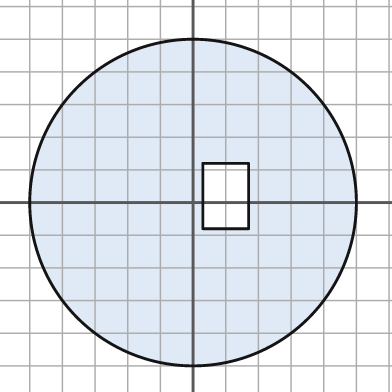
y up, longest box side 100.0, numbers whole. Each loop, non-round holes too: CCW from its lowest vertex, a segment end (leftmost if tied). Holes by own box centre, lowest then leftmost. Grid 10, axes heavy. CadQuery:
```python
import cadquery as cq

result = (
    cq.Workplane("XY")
    .moveTo(0.0, 0.0)
    .circle(50.0)
    .moveTo(3.0, -8.0)
    .lineTo(17.0, -8.0)
    .lineTo(17.0, 12.0)
    .lineTo(3.0, 12.0)
    .close()
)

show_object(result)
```